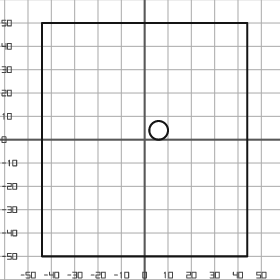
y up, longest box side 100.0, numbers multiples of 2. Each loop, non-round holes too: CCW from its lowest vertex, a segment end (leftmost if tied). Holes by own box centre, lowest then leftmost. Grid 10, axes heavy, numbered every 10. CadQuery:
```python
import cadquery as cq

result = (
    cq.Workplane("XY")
    .moveTo(-44.0, -50.0)
    .lineTo(44.0, -50.0)
    .lineTo(44.0, 50.0)
    .lineTo(-44.0, 50.0)
    .close()
    .moveTo(6.0, 4.0)
    .circle(4.0)
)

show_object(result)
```